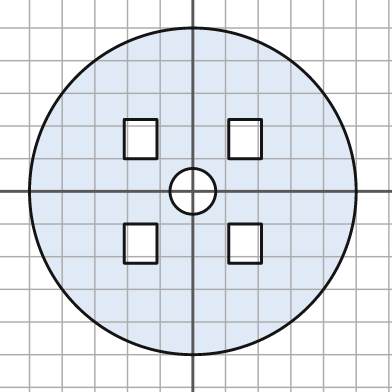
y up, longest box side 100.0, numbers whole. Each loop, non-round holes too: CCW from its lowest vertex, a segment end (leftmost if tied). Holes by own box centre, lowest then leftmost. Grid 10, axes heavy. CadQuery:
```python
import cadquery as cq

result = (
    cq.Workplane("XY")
    .moveTo(0.0, 0.0)
    .circle(50.0)
    .moveTo(-21.0, -22.0)
    .lineTo(-11.0, -22.0)
    .lineTo(-11.0, -10.0)
    .lineTo(-21.0, -10.0)
    .close()
    .moveTo(11.0, -22.0)
    .lineTo(21.0, -22.0)
    .lineTo(21.0, -10.0)
    .lineTo(11.0, -10.0)
    .close()
    .moveTo(0.0, 0.0)
    .circle(7.0)
    .moveTo(-21.0, 10.0)
    .lineTo(-11.0, 10.0)
    .lineTo(-11.0, 22.0)
    .lineTo(-21.0, 22.0)
    .close()
    .moveTo(11.0, 10.0)
    .lineTo(21.0, 10.0)
    .lineTo(21.0, 22.0)
    .lineTo(11.0, 22.0)
    .close()
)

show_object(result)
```